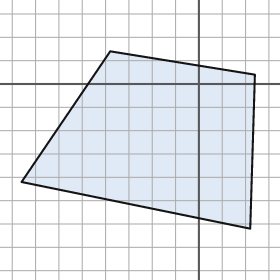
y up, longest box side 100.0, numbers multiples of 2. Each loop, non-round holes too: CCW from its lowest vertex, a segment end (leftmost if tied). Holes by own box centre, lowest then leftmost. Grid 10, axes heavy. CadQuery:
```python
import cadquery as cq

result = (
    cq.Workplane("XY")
    .moveTo(22.0, -62.0)
    .lineTo(24.0, 4.0)
    .lineTo(-38.0, 14.0)
    .lineTo(-76.0, -42.0)
    .close()
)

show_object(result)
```